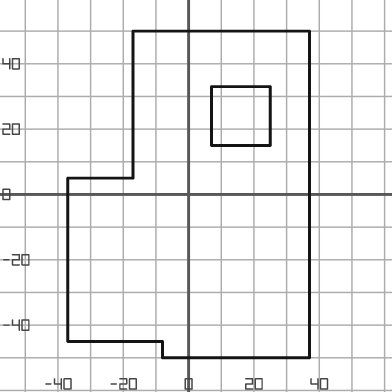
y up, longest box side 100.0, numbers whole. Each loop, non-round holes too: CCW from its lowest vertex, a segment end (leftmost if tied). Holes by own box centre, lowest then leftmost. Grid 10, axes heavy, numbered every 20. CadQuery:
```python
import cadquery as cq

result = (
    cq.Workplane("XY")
    .moveTo(-8.0, -50.0)
    .lineTo(37.0, -50.0)
    .lineTo(37.0, 50.0)
    .lineTo(-17.0, 50.0)
    .lineTo(-17.0, 5.0)
    .lineTo(-37.0, 5.0)
    .lineTo(-37.0, -45.0)
    .lineTo(-8.0, -45.0)
    .close()
    .moveTo(7.0, 15.0)
    .lineTo(25.0, 15.0)
    .lineTo(25.0, 33.0)
    .lineTo(7.0, 33.0)
    .close()
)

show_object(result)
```